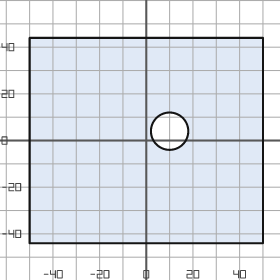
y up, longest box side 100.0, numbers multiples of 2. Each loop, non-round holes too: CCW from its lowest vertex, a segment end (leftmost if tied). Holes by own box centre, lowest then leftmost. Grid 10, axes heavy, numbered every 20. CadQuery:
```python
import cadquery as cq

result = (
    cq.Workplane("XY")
    .moveTo(-50.0, -44.0)
    .lineTo(50.0, -44.0)
    .lineTo(50.0, 44.0)
    .lineTo(-50.0, 44.0)
    .close()
    .moveTo(10.0, 4.0)
    .circle(8.0)
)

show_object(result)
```